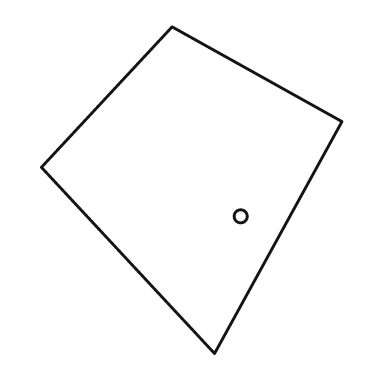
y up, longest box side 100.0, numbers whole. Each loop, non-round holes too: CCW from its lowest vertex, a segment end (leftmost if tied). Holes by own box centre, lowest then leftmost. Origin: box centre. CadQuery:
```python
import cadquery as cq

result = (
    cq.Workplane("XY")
    .moveTo(7.0, -50.0)
    .lineTo(46.0, 21.0)
    .lineTo(-6.0, 50.0)
    .lineTo(-46.0, 7.0)
    .close()
    .moveTo(15.0, -8.0)
    .circle(2.0)
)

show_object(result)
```